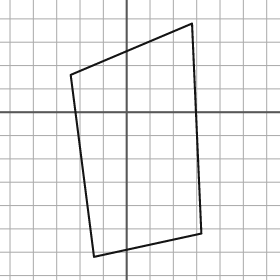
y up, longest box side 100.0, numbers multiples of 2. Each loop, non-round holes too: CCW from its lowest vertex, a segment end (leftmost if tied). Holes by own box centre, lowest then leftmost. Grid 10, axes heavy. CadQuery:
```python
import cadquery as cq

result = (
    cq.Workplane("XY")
    .moveTo(-14.0, -62.0)
    .lineTo(32.0, -52.0)
    .lineTo(28.0, 38.0)
    .lineTo(-24.0, 16.0)
    .close()
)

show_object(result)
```